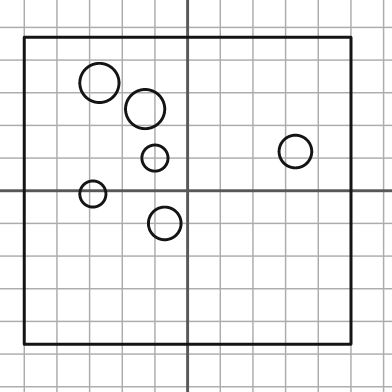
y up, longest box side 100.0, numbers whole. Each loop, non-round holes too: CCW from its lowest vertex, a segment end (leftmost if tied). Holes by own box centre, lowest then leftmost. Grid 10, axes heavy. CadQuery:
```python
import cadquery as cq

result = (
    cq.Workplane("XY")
    .moveTo(-50.0, -47.0)
    .lineTo(50.0, -47.0)
    .lineTo(50.0, 47.0)
    .lineTo(-50.0, 47.0)
    .close()
    .moveTo(-7.0, -10.0)
    .circle(5.0)
    .moveTo(-29.0, -1.0)
    .circle(4.0)
    .moveTo(-10.0, 10.0)
    .circle(4.0)
    .moveTo(33.0, 12.0)
    .circle(5.0)
    .moveTo(-13.0, 25.0)
    .circle(6.0)
    .moveTo(-27.0, 33.0)
    .circle(6.0)
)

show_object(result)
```